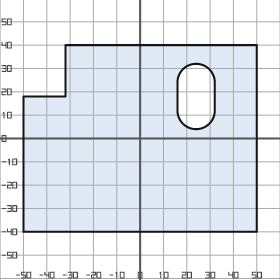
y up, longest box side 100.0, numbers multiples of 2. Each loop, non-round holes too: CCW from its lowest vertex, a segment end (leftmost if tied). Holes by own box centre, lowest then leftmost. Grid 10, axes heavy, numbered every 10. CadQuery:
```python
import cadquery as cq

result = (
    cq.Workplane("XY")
    .moveTo(-50.0, -40.0)
    .lineTo(50.0, -40.0)
    .lineTo(50.0, 40.0)
    .lineTo(-32.0, 40.0)
    .lineTo(-32.0, 18.0)
    .lineTo(-50.0, 18.0)
    .close()
    .moveTo(16.0, 12.0)
    .threePointArc((24.0, 4.0), (32.0, 12.0))
    .lineTo(32.0, 24.0)
    .threePointArc((24.0, 32.0), (16.0, 24.0))
    .close()
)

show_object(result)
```